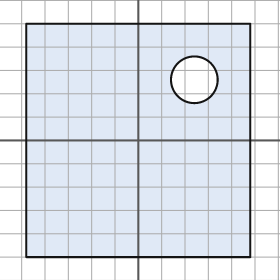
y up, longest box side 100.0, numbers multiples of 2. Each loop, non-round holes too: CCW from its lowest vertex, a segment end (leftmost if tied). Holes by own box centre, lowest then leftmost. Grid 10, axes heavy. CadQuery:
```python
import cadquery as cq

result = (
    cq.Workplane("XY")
    .moveTo(-48.0, -50.0)
    .lineTo(48.0, -50.0)
    .lineTo(48.0, 50.0)
    .lineTo(-48.0, 50.0)
    .close()
    .moveTo(24.0, 26.0)
    .circle(10.0)
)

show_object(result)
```